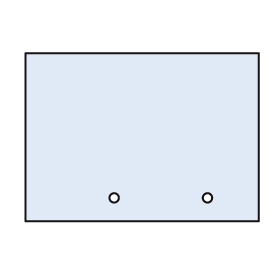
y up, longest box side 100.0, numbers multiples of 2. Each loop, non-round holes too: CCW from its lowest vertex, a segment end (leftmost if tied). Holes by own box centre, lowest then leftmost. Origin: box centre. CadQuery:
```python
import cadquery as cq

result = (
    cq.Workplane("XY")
    .moveTo(-50.0, -36.0)
    .lineTo(50.0, -36.0)
    .lineTo(50.0, 36.0)
    .lineTo(-50.0, 36.0)
    .close()
    .moveTo(-12.0, -26.0)
    .circle(2.0)
    .moveTo(28.0, -26.0)
    .circle(2.0)
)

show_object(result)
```